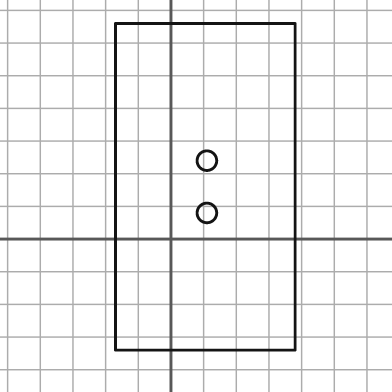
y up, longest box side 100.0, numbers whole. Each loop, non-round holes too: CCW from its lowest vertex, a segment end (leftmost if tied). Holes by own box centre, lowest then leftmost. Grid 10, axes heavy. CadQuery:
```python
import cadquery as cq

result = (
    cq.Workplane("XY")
    .moveTo(-17.0, -34.0)
    .lineTo(38.0, -34.0)
    .lineTo(38.0, 66.0)
    .lineTo(-17.0, 66.0)
    .close()
    .moveTo(11.0, 8.0)
    .circle(3.0)
    .moveTo(11.0, 24.0)
    .circle(3.0)
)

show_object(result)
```